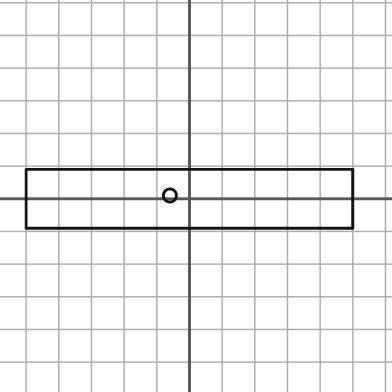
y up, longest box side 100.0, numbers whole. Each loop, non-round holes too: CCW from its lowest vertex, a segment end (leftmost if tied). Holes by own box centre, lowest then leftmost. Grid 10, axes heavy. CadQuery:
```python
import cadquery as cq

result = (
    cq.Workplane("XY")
    .moveTo(-50.0, -9.0)
    .lineTo(50.0, -9.0)
    .lineTo(50.0, 9.0)
    .lineTo(-50.0, 9.0)
    .close()
    .moveTo(-6.0, 1.0)
    .circle(2.0)
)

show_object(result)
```